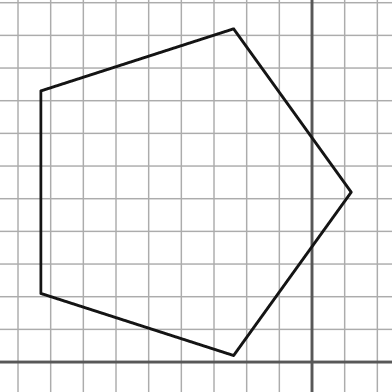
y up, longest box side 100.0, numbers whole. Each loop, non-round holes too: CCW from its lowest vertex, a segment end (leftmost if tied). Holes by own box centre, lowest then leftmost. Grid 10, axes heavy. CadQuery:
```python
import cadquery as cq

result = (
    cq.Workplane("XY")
    .moveTo(-24.0, 2.0)
    .lineTo(12.0, 52.0)
    .lineTo(-24.0, 102.0)
    .lineTo(-83.0, 83.0)
    .lineTo(-83.0, 21.0)
    .close()
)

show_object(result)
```